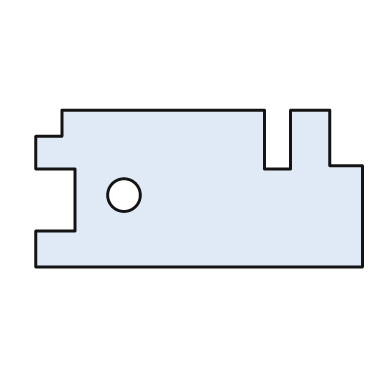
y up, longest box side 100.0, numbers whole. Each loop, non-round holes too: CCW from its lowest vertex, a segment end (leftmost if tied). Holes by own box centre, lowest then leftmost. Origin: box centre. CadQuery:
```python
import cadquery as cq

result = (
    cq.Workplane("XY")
    .moveTo(-50.0, -24.0)
    .lineTo(50.0, -24.0)
    .lineTo(50.0, 7.0)
    .lineTo(40.0, 7.0)
    .lineTo(40.0, 24.0)
    .lineTo(28.0, 24.0)
    .lineTo(28.0, 6.0)
    .lineTo(20.0, 6.0)
    .lineTo(20.0, 24.0)
    .lineTo(-42.0, 24.0)
    .lineTo(-42.0, 16.0)
    .lineTo(-50.0, 16.0)
    .lineTo(-50.0, 6.0)
    .lineTo(-38.0, 6.0)
    .lineTo(-38.0, -13.0)
    .lineTo(-50.0, -13.0)
    .close()
    .moveTo(-23.0, -2.0)
    .circle(5.0)
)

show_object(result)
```